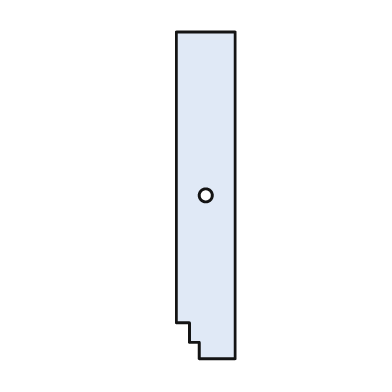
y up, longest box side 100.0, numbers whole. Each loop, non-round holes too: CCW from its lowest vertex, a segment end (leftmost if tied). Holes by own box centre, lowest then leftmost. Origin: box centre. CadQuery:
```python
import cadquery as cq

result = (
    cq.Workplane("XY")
    .moveTo(-2.0, -50.0)
    .lineTo(9.0, -50.0)
    .lineTo(9.0, 50.0)
    .lineTo(-9.0, 50.0)
    .lineTo(-9.0, -39.0)
    .lineTo(-5.0, -39.0)
    .lineTo(-5.0, -45.0)
    .lineTo(-2.0, -45.0)
    .close()
    .moveTo(0.0, 0.0)
    .circle(2.0)
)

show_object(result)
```